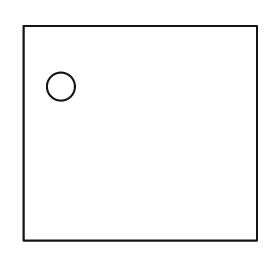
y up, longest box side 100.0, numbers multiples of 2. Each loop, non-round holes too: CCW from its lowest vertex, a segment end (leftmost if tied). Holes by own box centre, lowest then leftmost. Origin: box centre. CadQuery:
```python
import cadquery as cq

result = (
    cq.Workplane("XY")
    .moveTo(-50.0, -46.0)
    .lineTo(50.0, -46.0)
    .lineTo(50.0, 46.0)
    .lineTo(-50.0, 46.0)
    .close()
    .moveTo(-34.0, 20.0)
    .circle(6.0)
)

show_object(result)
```